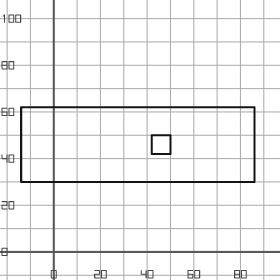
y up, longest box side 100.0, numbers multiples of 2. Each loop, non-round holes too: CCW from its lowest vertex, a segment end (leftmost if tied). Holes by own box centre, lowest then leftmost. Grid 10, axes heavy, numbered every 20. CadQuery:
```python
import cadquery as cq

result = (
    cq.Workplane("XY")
    .moveTo(-14.0, 30.0)
    .lineTo(86.0, 30.0)
    .lineTo(86.0, 62.0)
    .lineTo(-14.0, 62.0)
    .close()
    .moveTo(42.0, 42.0)
    .lineTo(50.0, 42.0)
    .lineTo(50.0, 50.0)
    .lineTo(42.0, 50.0)
    .close()
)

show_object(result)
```